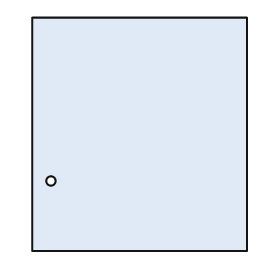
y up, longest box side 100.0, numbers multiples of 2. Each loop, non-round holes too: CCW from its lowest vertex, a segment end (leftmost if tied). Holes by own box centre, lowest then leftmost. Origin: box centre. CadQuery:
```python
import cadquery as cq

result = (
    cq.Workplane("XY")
    .moveTo(-46.0, -50.0)
    .lineTo(46.0, -50.0)
    .lineTo(46.0, 50.0)
    .lineTo(-46.0, 50.0)
    .close()
    .moveTo(-38.0, -20.0)
    .circle(2.0)
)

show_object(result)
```